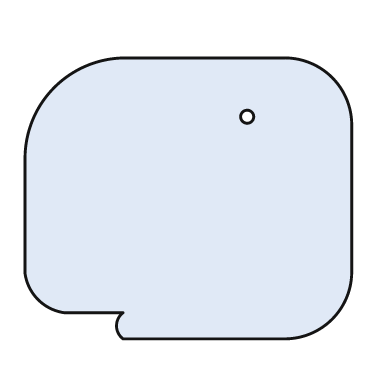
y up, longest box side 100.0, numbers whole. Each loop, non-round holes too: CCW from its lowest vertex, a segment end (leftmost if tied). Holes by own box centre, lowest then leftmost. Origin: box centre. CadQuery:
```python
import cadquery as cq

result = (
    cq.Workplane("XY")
    .moveTo(-20.0, -43.0)
    .lineTo(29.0, -43.0)
    .threePointArc((44.0, -37.0), (50.0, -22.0))
    .lineTo(50.0, 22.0)
    .threePointArc((44.0, 37.0), (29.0, 43.0))
    .lineTo(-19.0, 43.0)
    .threePointArc((-41.0, 34.0), (-50.0, 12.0))
    .lineTo(-50.0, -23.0)
    .threePointArc((-46.0, -31.0), (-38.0, -35.0))
    .lineTo(-20.0, -35.0)
    .threePointArc((-22.0, -39.0), (-20.0, -43.0))
    .close()
    .moveTo(18.0, 25.0)
    .circle(2.0)
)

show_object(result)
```